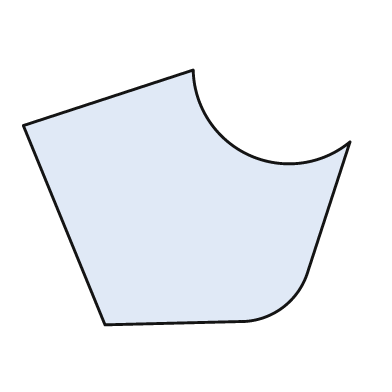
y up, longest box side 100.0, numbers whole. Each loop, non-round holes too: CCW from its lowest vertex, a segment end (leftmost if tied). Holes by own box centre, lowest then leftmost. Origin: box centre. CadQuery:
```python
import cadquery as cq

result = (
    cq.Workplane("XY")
    .moveTo(-25.0, -39.0)
    .lineTo(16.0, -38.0)
    .threePointArc((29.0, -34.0), (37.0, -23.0))
    .lineTo(50.0, 17.0)
    .threePointArc((19.0, 13.0), (2.0, 39.0))
    .lineTo(-50.0, 22.0)
    .close()
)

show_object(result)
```